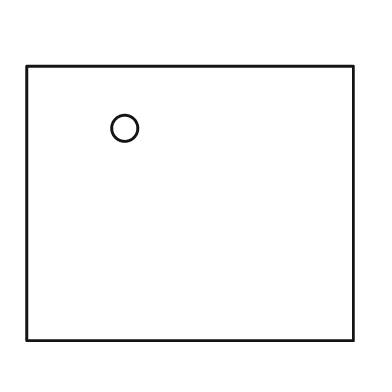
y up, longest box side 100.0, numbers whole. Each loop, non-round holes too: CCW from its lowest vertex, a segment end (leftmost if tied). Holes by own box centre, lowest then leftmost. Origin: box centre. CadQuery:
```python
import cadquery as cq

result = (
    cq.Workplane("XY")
    .moveTo(-50.0, -42.0)
    .lineTo(50.0, -42.0)
    .lineTo(50.0, 42.0)
    .lineTo(-50.0, 42.0)
    .close()
    .moveTo(-20.0, 23.0)
    .circle(4.0)
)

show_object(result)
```